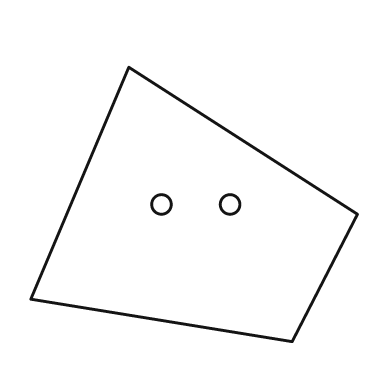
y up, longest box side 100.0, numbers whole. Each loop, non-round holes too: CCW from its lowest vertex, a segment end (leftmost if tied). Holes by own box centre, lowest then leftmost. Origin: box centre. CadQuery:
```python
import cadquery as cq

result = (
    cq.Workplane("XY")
    .moveTo(30.0, -42.0)
    .lineTo(50.0, -3.0)
    .lineTo(-20.0, 42.0)
    .lineTo(-50.0, -29.0)
    .close()
    .moveTo(-10.0, 0.0)
    .circle(3.0)
    .moveTo(11.0, 0.0)
    .circle(3.0)
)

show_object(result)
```